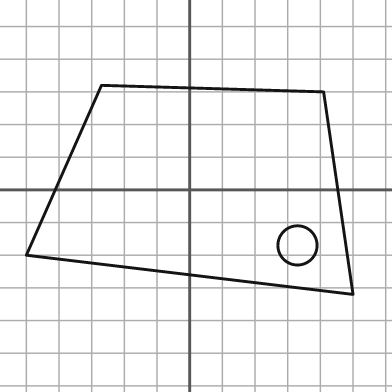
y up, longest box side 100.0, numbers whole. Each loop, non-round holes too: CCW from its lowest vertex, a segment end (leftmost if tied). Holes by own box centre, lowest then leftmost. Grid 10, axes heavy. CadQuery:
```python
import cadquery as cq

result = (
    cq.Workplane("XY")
    .moveTo(50.0, -32.0)
    .lineTo(41.0, 30.0)
    .lineTo(-27.0, 32.0)
    .lineTo(-50.0, -20.0)
    .close()
    .moveTo(33.0, -17.0)
    .circle(6.0)
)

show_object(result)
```